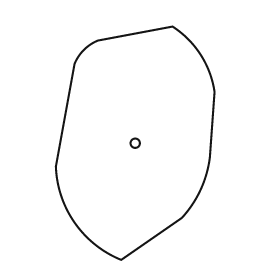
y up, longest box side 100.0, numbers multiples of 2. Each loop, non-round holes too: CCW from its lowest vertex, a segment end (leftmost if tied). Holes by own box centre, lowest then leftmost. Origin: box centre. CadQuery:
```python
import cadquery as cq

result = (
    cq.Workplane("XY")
    .moveTo(-6.0, -50.0)
    .lineTo(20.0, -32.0)
    .threePointArc((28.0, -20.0), (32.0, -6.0))
    .lineTo(34.0, 22.0)
    .threePointArc((28.0, 38.0), (16.0, 50.0))
    .lineTo(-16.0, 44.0)
    .threePointArc((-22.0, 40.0), (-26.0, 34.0))
    .lineTo(-34.0, -10.0)
    .threePointArc((-26.0, -34.0), (-6.0, -50.0))
    .close()
    .moveTo(0.0, 0.0)
    .circle(2.0)
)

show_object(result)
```